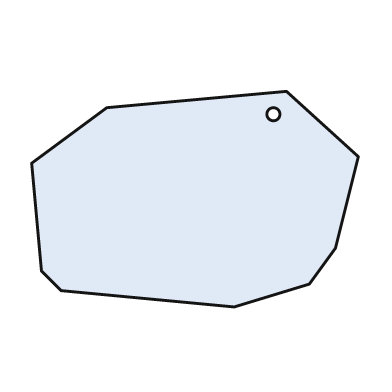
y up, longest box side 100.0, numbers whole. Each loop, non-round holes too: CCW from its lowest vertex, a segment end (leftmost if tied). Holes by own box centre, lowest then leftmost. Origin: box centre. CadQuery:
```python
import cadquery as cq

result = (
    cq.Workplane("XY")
    .moveTo(12.0, -33.0)
    .lineTo(35.0, -26.0)
    .lineTo(43.0, -15.0)
    .lineTo(50.0, 13.0)
    .lineTo(28.0, 33.0)
    .lineTo(-27.0, 28.0)
    .lineTo(-50.0, 11.0)
    .lineTo(-47.0, -22.0)
    .lineTo(-41.0, -28.0)
    .close()
    .moveTo(24.0, 26.0)
    .circle(2.0)
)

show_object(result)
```